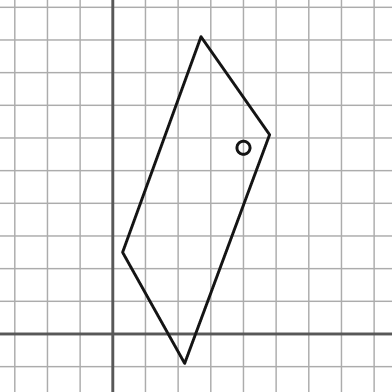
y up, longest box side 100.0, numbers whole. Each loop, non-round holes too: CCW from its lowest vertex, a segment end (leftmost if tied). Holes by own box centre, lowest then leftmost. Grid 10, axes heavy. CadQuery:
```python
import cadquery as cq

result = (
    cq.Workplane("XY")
    .moveTo(22.0, -9.0)
    .lineTo(48.0, 61.0)
    .lineTo(27.0, 91.0)
    .lineTo(3.0, 25.0)
    .close()
    .moveTo(40.0, 57.0)
    .circle(2.0)
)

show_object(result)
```